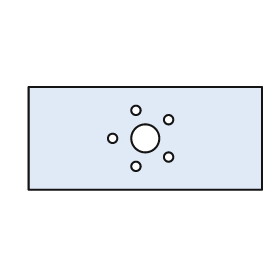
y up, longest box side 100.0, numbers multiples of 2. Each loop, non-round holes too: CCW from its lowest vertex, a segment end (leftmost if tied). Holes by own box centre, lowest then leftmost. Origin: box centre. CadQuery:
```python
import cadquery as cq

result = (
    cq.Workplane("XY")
    .moveTo(-50.0, -22.0)
    .lineTo(50.0, -22.0)
    .lineTo(50.0, 22.0)
    .lineTo(-50.0, 22.0)
    .close()
    .moveTo(-4.0, -12.0)
    .circle(2.0)
    .moveTo(10.0, -8.0)
    .circle(2.0)
    .moveTo(-14.0, 0.0)
    .circle(2.0)
    .moveTo(0.0, 0.0)
    .circle(6.0)
    .moveTo(10.0, 8.0)
    .circle(2.0)
    .moveTo(-4.0, 12.0)
    .circle(2.0)
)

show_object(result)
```